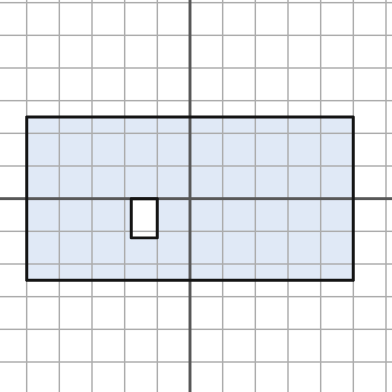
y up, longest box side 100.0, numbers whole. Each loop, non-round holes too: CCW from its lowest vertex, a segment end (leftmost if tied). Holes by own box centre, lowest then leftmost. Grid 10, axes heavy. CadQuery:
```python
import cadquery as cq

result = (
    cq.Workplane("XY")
    .moveTo(-50.0, -25.0)
    .lineTo(50.0, -25.0)
    .lineTo(50.0, 25.0)
    .lineTo(-50.0, 25.0)
    .close()
    .moveTo(-18.0, -12.0)
    .lineTo(-10.0, -12.0)
    .lineTo(-10.0, 0.0)
    .lineTo(-18.0, 0.0)
    .close()
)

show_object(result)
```